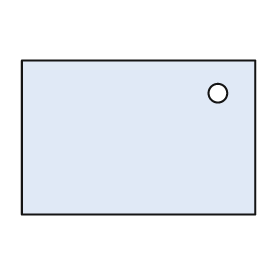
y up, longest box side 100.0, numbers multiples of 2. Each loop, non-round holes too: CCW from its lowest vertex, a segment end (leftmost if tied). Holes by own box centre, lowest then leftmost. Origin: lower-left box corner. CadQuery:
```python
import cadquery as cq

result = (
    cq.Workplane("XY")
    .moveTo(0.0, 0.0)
    .lineTo(100.0, 0.0)
    .lineTo(100.0, 66.0)
    .lineTo(0.0, 66.0)
    .close()
    .moveTo(84.0, 52.0)
    .circle(4.0)
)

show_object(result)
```